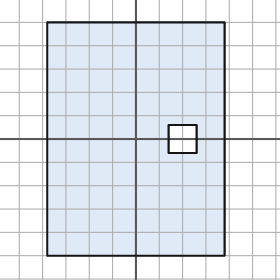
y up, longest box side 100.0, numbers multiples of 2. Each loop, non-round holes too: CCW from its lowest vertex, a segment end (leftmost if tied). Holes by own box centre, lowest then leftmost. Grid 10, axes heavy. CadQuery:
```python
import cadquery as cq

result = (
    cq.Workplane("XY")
    .moveTo(-38.0, -50.0)
    .lineTo(38.0, -50.0)
    .lineTo(38.0, 50.0)
    .lineTo(-38.0, 50.0)
    .close()
    .moveTo(14.0, -6.0)
    .lineTo(26.0, -6.0)
    .lineTo(26.0, 6.0)
    .lineTo(14.0, 6.0)
    .close()
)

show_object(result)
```